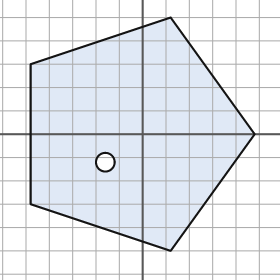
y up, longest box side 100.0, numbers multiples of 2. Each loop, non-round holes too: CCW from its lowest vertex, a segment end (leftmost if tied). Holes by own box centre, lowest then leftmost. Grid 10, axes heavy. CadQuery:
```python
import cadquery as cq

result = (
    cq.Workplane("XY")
    .moveTo(12.0, -50.0)
    .lineTo(48.0, 0.0)
    .lineTo(12.0, 50.0)
    .lineTo(-48.0, 30.0)
    .lineTo(-48.0, -30.0)
    .close()
    .moveTo(-16.0, -12.0)
    .circle(4.0)
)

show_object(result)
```